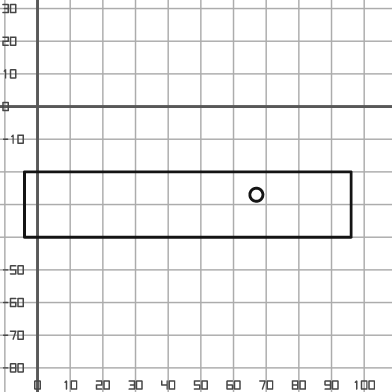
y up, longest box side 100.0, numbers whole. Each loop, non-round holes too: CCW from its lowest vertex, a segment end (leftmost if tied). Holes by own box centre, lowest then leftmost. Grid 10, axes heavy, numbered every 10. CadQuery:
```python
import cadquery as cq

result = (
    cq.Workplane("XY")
    .moveTo(-4.0, -40.0)
    .lineTo(96.0, -40.0)
    .lineTo(96.0, -20.0)
    .lineTo(-4.0, -20.0)
    .close()
    .moveTo(67.0, -27.0)
    .circle(2.0)
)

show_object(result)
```